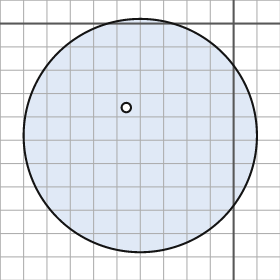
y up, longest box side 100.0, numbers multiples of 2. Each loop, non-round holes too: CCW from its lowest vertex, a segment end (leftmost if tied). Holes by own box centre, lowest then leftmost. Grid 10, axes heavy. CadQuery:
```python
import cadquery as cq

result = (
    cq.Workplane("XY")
    .moveTo(-40.0, -48.0)
    .circle(50.0)
    .moveTo(-46.0, -36.0)
    .circle(2.0)
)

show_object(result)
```